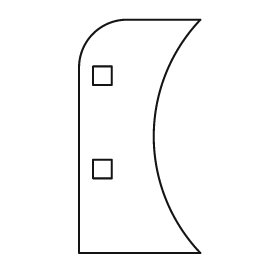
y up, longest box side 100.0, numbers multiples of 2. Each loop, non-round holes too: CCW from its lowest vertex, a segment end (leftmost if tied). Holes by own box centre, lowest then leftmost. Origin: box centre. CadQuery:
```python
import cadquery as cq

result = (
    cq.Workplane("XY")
    .moveTo(-26.0, -50.0)
    .lineTo(26.0, -50.0)
    .threePointArc((6.0, 0.0), (26.0, 50.0))
    .lineTo(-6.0, 50.0)
    .threePointArc((-20.0, 44.0), (-26.0, 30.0))
    .close()
    .moveTo(-20.0, -18.0)
    .lineTo(-12.0, -18.0)
    .lineTo(-12.0, -10.0)
    .lineTo(-20.0, -10.0)
    .close()
    .moveTo(-20.0, 22.0)
    .lineTo(-12.0, 22.0)
    .lineTo(-12.0, 30.0)
    .lineTo(-20.0, 30.0)
    .close()
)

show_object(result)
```